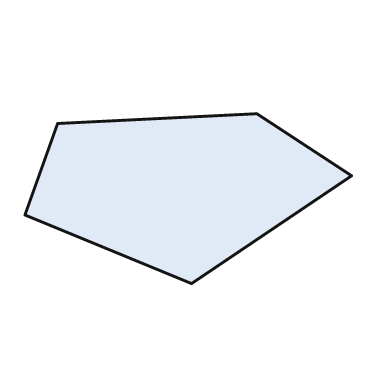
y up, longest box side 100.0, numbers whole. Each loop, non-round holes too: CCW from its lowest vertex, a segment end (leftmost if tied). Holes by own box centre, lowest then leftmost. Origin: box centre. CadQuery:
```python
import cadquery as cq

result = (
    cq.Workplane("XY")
    .moveTo(1.0, -26.0)
    .lineTo(50.0, 7.0)
    .lineTo(21.0, 26.0)
    .lineTo(-40.0, 23.0)
    .lineTo(-50.0, -5.0)
    .close()
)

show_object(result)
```